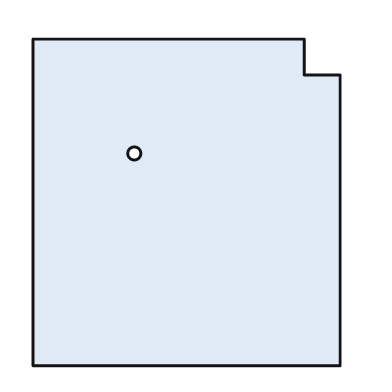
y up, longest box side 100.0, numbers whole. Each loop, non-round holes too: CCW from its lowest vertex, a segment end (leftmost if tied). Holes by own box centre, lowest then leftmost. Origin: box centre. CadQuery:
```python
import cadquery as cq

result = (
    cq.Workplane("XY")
    .moveTo(-47.0, -50.0)
    .lineTo(47.0, -50.0)
    .lineTo(47.0, 39.0)
    .lineTo(36.0, 39.0)
    .lineTo(36.0, 50.0)
    .lineTo(-47.0, 50.0)
    .close()
    .moveTo(-16.0, 15.0)
    .circle(2.0)
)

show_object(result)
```